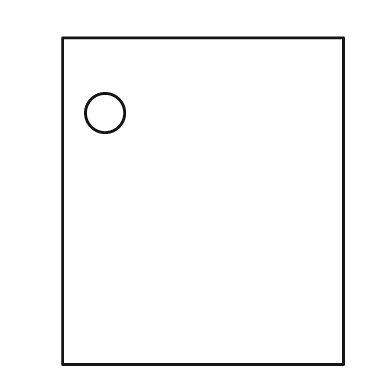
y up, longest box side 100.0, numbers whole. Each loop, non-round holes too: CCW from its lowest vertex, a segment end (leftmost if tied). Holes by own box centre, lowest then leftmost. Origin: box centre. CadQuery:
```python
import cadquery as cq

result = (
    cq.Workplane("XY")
    .moveTo(-43.0, -50.0)
    .lineTo(43.0, -50.0)
    .lineTo(43.0, 50.0)
    .lineTo(-43.0, 50.0)
    .close()
    .moveTo(-30.0, 27.0)
    .circle(6.0)
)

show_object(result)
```